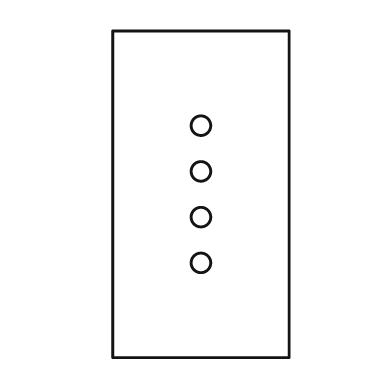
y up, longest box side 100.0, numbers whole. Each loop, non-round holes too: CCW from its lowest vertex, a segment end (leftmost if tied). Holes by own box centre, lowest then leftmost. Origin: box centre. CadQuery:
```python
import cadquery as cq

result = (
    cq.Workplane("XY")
    .moveTo(-27.0, -50.0)
    .lineTo(27.0, -50.0)
    .lineTo(27.0, 50.0)
    .lineTo(-27.0, 50.0)
    .close()
    .moveTo(0.0, -21.0)
    .circle(3.0)
    .moveTo(0.0, -7.0)
    .circle(3.0)
    .moveTo(0.0, 7.0)
    .circle(3.0)
    .moveTo(0.0, 21.0)
    .circle(3.0)
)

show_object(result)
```